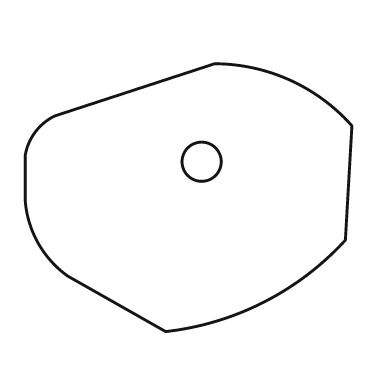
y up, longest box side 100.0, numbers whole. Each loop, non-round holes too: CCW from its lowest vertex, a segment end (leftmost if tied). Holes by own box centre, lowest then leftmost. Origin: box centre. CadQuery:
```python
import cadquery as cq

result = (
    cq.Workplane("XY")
    .moveTo(-7.0, -41.0)
    .threePointArc((23.0, -32.0), (48.0, -13.0))
    .lineTo(50.0, 22.0)
    .threePointArc((31.0, 36.0), (8.0, 41.0))
    .lineTo(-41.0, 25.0)
    .threePointArc((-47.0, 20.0), (-50.0, 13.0))
    .lineTo(-50.0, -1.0)
    .threePointArc((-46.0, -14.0), (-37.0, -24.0))
    .close()
    .moveTo(4.0, 11.0)
    .circle(6.0)
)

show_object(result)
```